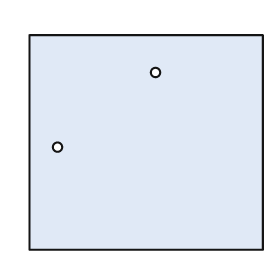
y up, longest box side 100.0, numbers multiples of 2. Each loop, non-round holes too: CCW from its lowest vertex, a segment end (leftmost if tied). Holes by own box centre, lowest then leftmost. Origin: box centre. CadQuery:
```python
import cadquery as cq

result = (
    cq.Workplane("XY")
    .moveTo(-50.0, -46.0)
    .lineTo(50.0, -46.0)
    .lineTo(50.0, 46.0)
    .lineTo(-50.0, 46.0)
    .close()
    .moveTo(-38.0, -2.0)
    .circle(2.0)
    .moveTo(4.0, 30.0)
    .circle(2.0)
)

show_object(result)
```